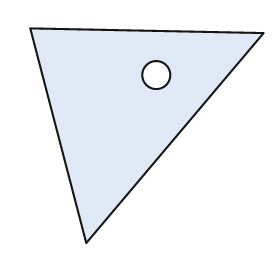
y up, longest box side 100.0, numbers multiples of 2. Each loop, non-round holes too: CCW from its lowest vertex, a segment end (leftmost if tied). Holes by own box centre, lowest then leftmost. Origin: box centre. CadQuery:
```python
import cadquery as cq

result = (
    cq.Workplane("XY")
    .moveTo(-26.0, -46.0)
    .lineTo(50.0, 44.0)
    .lineTo(-50.0, 46.0)
    .close()
    .moveTo(4.0, 26.0)
    .circle(6.0)
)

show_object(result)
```